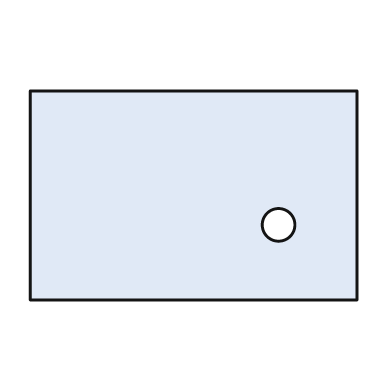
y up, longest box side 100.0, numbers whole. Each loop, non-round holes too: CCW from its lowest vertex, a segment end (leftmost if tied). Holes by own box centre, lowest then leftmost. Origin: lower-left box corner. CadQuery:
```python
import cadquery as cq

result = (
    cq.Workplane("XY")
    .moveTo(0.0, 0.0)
    .lineTo(100.0, 0.0)
    .lineTo(100.0, 64.0)
    .lineTo(0.0, 64.0)
    .close()
    .moveTo(76.0, 23.0)
    .circle(5.0)
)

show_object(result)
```